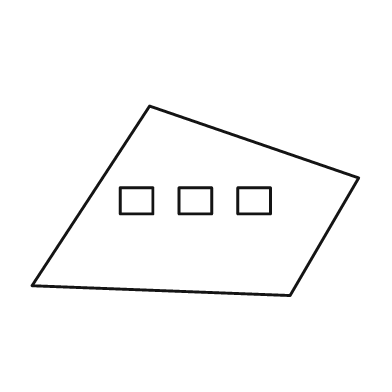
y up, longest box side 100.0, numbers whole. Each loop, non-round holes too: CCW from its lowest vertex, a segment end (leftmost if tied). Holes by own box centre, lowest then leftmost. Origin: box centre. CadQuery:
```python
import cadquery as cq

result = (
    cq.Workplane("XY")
    .moveTo(29.0, -29.0)
    .lineTo(50.0, 7.0)
    .lineTo(-14.0, 29.0)
    .lineTo(-50.0, -26.0)
    .close()
    .moveTo(-23.0, -4.0)
    .lineTo(-13.0, -4.0)
    .lineTo(-13.0, 4.0)
    .lineTo(-23.0, 4.0)
    .close()
    .moveTo(-5.0, -4.0)
    .lineTo(5.0, -4.0)
    .lineTo(5.0, 4.0)
    .lineTo(-5.0, 4.0)
    .close()
    .moveTo(13.0, -4.0)
    .lineTo(23.0, -4.0)
    .lineTo(23.0, 4.0)
    .lineTo(13.0, 4.0)
    .close()
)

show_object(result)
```